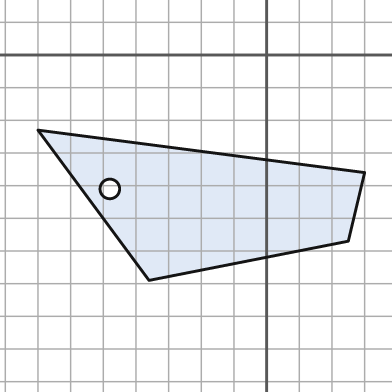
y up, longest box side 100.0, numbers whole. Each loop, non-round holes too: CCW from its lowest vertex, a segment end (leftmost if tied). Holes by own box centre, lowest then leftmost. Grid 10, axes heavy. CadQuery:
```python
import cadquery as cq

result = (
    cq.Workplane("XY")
    .moveTo(-36.0, -69.0)
    .lineTo(25.0, -57.0)
    .lineTo(30.0, -36.0)
    .lineTo(-70.0, -23.0)
    .close()
    .moveTo(-48.0, -41.0)
    .circle(3.0)
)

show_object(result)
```